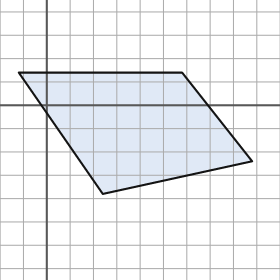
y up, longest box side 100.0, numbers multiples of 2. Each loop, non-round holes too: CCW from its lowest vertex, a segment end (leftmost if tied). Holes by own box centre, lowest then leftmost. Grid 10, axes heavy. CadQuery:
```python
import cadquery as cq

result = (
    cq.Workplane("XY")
    .moveTo(24.0, -38.0)
    .lineTo(88.0, -24.0)
    .lineTo(58.0, 14.0)
    .lineTo(-12.0, 14.0)
    .close()
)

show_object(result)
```